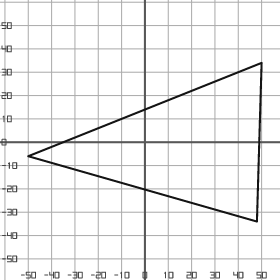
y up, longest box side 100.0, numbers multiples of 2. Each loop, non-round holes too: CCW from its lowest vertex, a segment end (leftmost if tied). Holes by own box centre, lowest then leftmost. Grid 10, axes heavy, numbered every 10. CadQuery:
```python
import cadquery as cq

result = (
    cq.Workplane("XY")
    .moveTo(48.0, -34.0)
    .lineTo(50.0, 34.0)
    .lineTo(-50.0, -6.0)
    .close()
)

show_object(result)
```